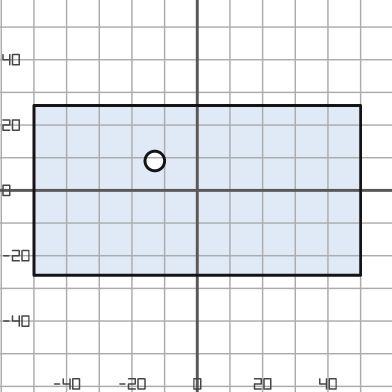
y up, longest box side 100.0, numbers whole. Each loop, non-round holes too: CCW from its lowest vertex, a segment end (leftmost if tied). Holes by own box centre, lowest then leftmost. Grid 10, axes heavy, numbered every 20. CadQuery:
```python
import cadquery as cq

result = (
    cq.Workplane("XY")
    .moveTo(-50.0, -26.0)
    .lineTo(50.0, -26.0)
    .lineTo(50.0, 26.0)
    .lineTo(-50.0, 26.0)
    .close()
    .moveTo(-13.0, 9.0)
    .circle(3.0)
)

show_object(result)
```